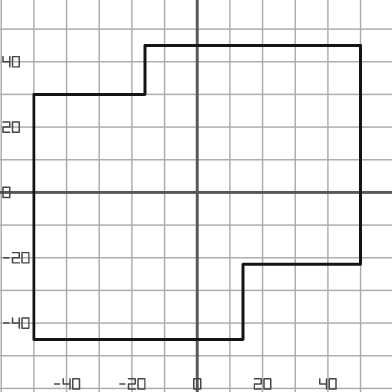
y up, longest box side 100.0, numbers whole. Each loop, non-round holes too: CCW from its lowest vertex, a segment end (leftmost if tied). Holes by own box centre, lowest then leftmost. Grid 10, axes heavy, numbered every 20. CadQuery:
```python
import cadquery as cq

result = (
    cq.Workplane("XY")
    .moveTo(-50.0, -45.0)
    .lineTo(14.0, -45.0)
    .lineTo(14.0, -22.0)
    .lineTo(50.0, -22.0)
    .lineTo(50.0, 45.0)
    .lineTo(-16.0, 45.0)
    .lineTo(-16.0, 30.0)
    .lineTo(-50.0, 30.0)
    .close()
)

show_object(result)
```